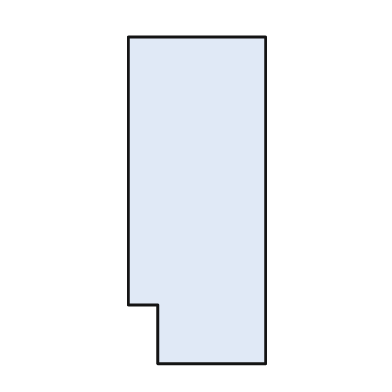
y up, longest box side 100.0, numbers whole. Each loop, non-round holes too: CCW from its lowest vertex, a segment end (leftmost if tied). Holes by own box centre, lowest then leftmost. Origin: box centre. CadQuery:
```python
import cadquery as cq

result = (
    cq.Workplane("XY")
    .moveTo(-12.0, -50.0)
    .lineTo(21.0, -50.0)
    .lineTo(21.0, 50.0)
    .lineTo(-21.0, 50.0)
    .lineTo(-21.0, -32.0)
    .lineTo(-12.0, -32.0)
    .close()
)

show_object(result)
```